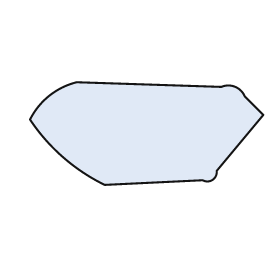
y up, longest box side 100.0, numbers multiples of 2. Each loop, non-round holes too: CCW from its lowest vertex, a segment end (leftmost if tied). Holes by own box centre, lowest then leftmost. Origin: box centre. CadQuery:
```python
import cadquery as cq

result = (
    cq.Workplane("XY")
    .moveTo(-18.0, -22.0)
    .lineTo(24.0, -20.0)
    .threePointArc((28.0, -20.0), (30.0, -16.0))
    .lineTo(50.0, 8.0)
    .lineTo(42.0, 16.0)
    .threePointArc((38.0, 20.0), (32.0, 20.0))
    .lineTo(-30.0, 22.0)
    .threePointArc((-42.0, 16.0), (-50.0, 6.0))
    .threePointArc((-36.0, -10.0), (-18.0, -22.0))
    .close()
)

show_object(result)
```